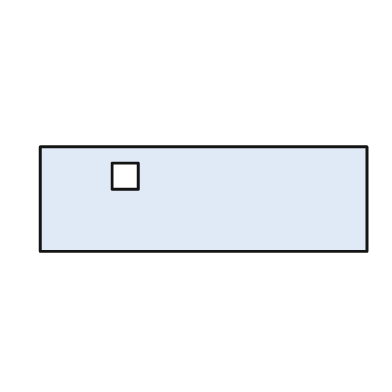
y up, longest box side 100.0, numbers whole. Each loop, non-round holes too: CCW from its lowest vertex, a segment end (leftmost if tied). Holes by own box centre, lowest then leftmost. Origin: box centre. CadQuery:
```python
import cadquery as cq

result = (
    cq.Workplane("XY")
    .moveTo(-50.0, -16.0)
    .lineTo(50.0, -16.0)
    .lineTo(50.0, 16.0)
    .lineTo(-50.0, 16.0)
    .close()
    .moveTo(-28.0, 3.0)
    .lineTo(-20.0, 3.0)
    .lineTo(-20.0, 11.0)
    .lineTo(-28.0, 11.0)
    .close()
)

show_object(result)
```